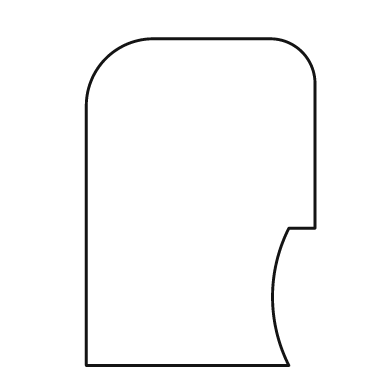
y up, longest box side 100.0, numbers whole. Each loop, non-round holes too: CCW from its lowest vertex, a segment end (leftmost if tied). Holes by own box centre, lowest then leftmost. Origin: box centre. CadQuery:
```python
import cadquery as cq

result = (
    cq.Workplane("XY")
    .moveTo(-35.0, -50.0)
    .lineTo(27.0, -50.0)
    .threePointArc((22.0, -29.0), (27.0, -8.0))
    .lineTo(35.0, -8.0)
    .lineTo(35.0, 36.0)
    .threePointArc((31.0, 46.0), (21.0, 50.0))
    .lineTo(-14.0, 50.0)
    .threePointArc((-29.0, 44.0), (-35.0, 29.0))
    .close()
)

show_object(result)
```